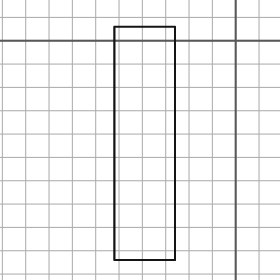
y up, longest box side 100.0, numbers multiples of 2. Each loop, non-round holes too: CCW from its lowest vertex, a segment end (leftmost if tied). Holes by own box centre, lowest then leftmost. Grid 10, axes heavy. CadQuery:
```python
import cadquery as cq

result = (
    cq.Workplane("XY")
    .moveTo(-52.0, -94.0)
    .lineTo(-26.0, -94.0)
    .lineTo(-26.0, 6.0)
    .lineTo(-52.0, 6.0)
    .close()
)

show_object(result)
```